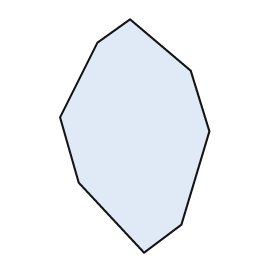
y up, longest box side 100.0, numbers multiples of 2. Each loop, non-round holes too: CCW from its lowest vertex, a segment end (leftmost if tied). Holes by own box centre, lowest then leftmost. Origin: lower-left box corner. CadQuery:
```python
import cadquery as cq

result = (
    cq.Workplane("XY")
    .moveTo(36.0, 0.0)
    .lineTo(52.0, 12.0)
    .lineTo(64.0, 52.0)
    .lineTo(56.0, 78.0)
    .lineTo(30.0, 100.0)
    .lineTo(16.0, 90.0)
    .lineTo(0.0, 58.0)
    .lineTo(8.0, 30.0)
    .close()
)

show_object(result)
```